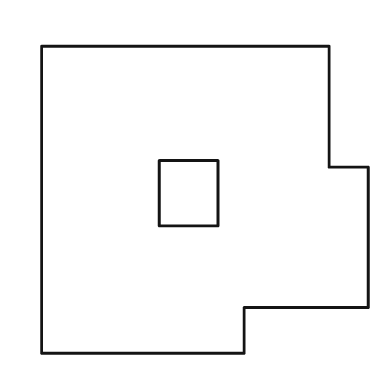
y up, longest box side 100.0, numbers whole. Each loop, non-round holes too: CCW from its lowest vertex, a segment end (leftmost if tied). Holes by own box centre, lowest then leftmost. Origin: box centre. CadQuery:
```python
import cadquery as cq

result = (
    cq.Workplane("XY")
    .moveTo(-50.0, -47.0)
    .lineTo(12.0, -47.0)
    .lineTo(12.0, -33.0)
    .lineTo(50.0, -33.0)
    .lineTo(50.0, 10.0)
    .lineTo(38.0, 10.0)
    .lineTo(38.0, 47.0)
    .lineTo(-50.0, 47.0)
    .close()
    .moveTo(-14.0, -8.0)
    .lineTo(4.0, -8.0)
    .lineTo(4.0, 12.0)
    .lineTo(-14.0, 12.0)
    .close()
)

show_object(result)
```